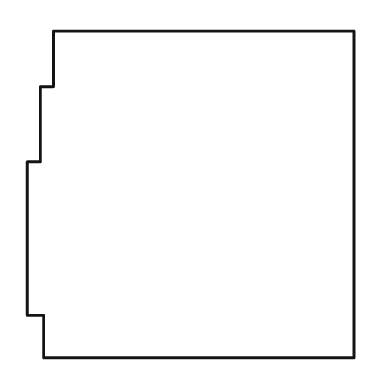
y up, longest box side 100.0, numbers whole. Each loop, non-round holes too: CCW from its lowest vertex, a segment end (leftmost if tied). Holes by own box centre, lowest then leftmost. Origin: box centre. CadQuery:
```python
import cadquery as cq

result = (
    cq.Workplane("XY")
    .moveTo(-45.0, -50.0)
    .lineTo(50.0, -50.0)
    .lineTo(50.0, 50.0)
    .lineTo(-42.0, 50.0)
    .lineTo(-42.0, 33.0)
    .lineTo(-46.0, 33.0)
    .lineTo(-46.0, 10.0)
    .lineTo(-50.0, 10.0)
    .lineTo(-50.0, -37.0)
    .lineTo(-45.0, -37.0)
    .close()
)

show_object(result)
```